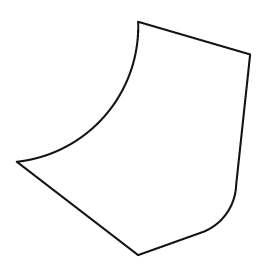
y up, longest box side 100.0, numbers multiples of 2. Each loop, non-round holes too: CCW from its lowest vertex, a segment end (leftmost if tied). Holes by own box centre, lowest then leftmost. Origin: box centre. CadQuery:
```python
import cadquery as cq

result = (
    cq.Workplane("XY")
    .moveTo(2.0, -50.0)
    .lineTo(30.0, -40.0)
    .threePointArc((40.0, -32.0), (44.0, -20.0))
    .lineTo(50.0, 36.0)
    .lineTo(2.0, 50.0)
    .threePointArc((-12.0, 10.0), (-50.0, -10.0))
    .close()
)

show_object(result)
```